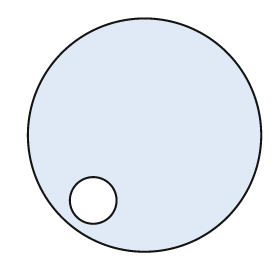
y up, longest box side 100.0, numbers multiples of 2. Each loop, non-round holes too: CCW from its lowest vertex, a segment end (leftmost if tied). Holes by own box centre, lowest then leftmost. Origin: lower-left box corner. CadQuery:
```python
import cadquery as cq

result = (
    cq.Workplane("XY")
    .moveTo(50.0, 50.0)
    .circle(50.0)
    .moveTo(28.0, 22.0)
    .circle(10.0)
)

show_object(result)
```